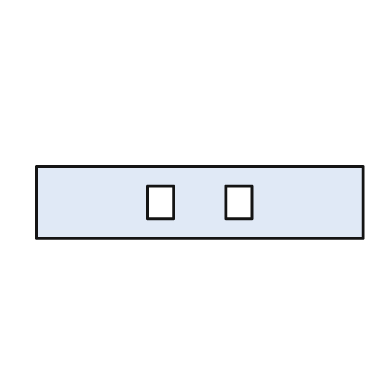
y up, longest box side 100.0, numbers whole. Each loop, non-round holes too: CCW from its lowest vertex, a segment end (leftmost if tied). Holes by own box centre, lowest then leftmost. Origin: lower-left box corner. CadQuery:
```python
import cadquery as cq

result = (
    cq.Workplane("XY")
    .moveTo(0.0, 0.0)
    .lineTo(100.0, 0.0)
    .lineTo(100.0, 22.0)
    .lineTo(0.0, 22.0)
    .close()
    .moveTo(34.0, 6.0)
    .lineTo(42.0, 6.0)
    .lineTo(42.0, 16.0)
    .lineTo(34.0, 16.0)
    .close()
    .moveTo(58.0, 6.0)
    .lineTo(66.0, 6.0)
    .lineTo(66.0, 16.0)
    .lineTo(58.0, 16.0)
    .close()
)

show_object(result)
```